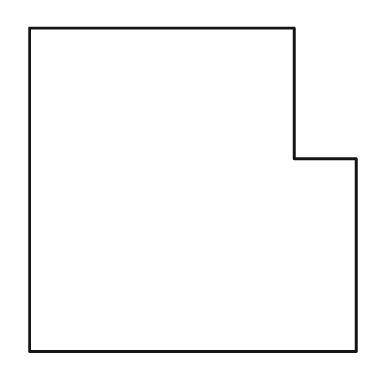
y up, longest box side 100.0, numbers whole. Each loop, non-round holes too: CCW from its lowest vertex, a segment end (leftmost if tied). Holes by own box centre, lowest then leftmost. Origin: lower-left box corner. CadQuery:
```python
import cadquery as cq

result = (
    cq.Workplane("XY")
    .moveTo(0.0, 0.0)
    .lineTo(100.0, 0.0)
    .lineTo(100.0, 59.0)
    .lineTo(81.0, 59.0)
    .lineTo(81.0, 99.0)
    .lineTo(0.0, 99.0)
    .close()
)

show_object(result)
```